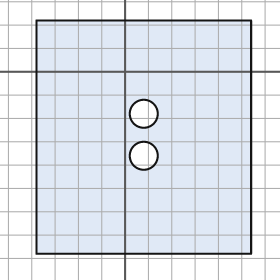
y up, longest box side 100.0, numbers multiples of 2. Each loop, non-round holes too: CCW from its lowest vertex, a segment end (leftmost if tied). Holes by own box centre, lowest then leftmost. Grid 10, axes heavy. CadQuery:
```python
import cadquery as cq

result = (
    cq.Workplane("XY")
    .moveTo(-38.0, -78.0)
    .lineTo(54.0, -78.0)
    .lineTo(54.0, 22.0)
    .lineTo(-38.0, 22.0)
    .close()
    .moveTo(8.0, -36.0)
    .circle(6.0)
    .moveTo(8.0, -18.0)
    .circle(6.0)
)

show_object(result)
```